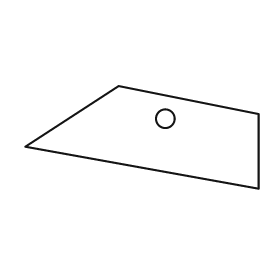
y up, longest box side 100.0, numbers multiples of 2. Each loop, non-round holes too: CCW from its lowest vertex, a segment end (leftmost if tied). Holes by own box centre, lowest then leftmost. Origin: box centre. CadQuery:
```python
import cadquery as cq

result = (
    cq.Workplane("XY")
    .moveTo(50.0, -22.0)
    .lineTo(50.0, 10.0)
    .lineTo(-10.0, 22.0)
    .lineTo(-50.0, -4.0)
    .close()
    .moveTo(10.0, 8.0)
    .circle(4.0)
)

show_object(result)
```